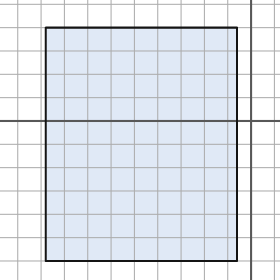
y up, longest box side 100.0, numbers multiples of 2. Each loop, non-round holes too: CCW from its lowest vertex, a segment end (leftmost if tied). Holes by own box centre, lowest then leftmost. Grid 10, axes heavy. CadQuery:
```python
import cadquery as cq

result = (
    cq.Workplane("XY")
    .moveTo(-88.0, -60.0)
    .lineTo(-6.0, -60.0)
    .lineTo(-6.0, 40.0)
    .lineTo(-88.0, 40.0)
    .close()
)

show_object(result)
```